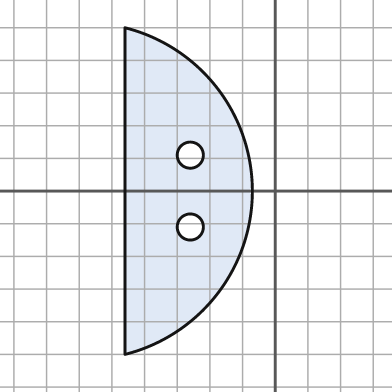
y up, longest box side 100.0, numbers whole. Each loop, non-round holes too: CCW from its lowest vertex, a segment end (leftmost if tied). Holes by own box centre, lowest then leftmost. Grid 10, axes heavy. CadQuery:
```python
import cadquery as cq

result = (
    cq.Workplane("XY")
    .moveTo(-46.0, -50.0)
    .threePointArc((-7.0, 0.0), (-46.0, 50.0))
    .close()
    .moveTo(-26.0, -11.0)
    .circle(4.0)
    .moveTo(-26.0, 11.0)
    .circle(4.0)
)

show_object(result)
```